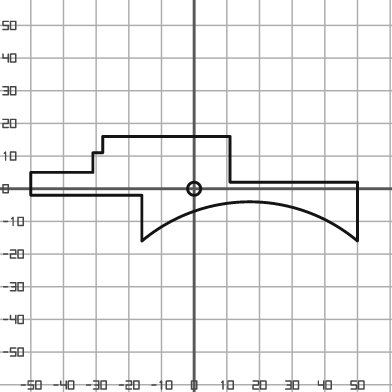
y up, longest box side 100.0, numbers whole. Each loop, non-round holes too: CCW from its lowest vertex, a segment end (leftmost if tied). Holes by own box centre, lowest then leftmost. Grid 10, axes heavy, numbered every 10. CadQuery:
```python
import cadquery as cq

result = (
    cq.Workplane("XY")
    .moveTo(-16.0, -16.0)
    .threePointArc((17.0, -4.0), (50.0, -16.0))
    .lineTo(50.0, 2.0)
    .lineTo(11.0, 2.0)
    .lineTo(11.0, 16.0)
    .lineTo(-28.0, 16.0)
    .lineTo(-28.0, 11.0)
    .lineTo(-31.0, 11.0)
    .lineTo(-31.0, 5.0)
    .lineTo(-50.0, 5.0)
    .lineTo(-50.0, -2.0)
    .lineTo(-16.0, -2.0)
    .close()
    .moveTo(0.0, 0.0)
    .circle(2.0)
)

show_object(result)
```